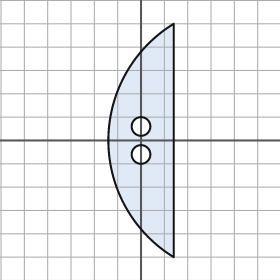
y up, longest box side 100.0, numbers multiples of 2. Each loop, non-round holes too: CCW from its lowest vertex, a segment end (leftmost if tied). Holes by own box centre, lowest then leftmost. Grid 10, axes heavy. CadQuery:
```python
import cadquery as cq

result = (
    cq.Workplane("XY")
    .moveTo(14.0, -50.0)
    .lineTo(14.0, 50.0)
    .threePointArc((-14.0, 0.0), (14.0, -50.0))
    .close()
    .moveTo(0.0, -6.0)
    .circle(4.0)
    .moveTo(0.0, 6.0)
    .circle(4.0)
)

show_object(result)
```